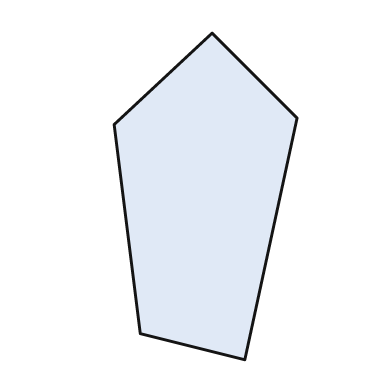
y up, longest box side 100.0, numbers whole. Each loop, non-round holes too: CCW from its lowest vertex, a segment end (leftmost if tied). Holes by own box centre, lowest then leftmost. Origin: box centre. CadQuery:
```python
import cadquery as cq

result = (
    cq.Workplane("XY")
    .moveTo(12.0, -50.0)
    .lineTo(28.0, 24.0)
    .lineTo(2.0, 50.0)
    .lineTo(-28.0, 22.0)
    .lineTo(-20.0, -42.0)
    .close()
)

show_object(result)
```